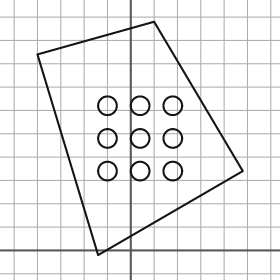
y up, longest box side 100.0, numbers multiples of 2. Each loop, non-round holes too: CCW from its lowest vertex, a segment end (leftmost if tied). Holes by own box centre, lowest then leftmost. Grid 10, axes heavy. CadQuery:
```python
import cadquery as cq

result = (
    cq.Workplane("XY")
    .moveTo(-14.0, -2.0)
    .lineTo(48.0, 34.0)
    .lineTo(10.0, 98.0)
    .lineTo(-40.0, 84.0)
    .close()
    .moveTo(-10.0, 34.0)
    .circle(4.0)
    .moveTo(4.0, 34.0)
    .circle(4.0)
    .moveTo(18.0, 34.0)
    .circle(4.0)
    .moveTo(-10.0, 48.0)
    .circle(4.0)
    .moveTo(4.0, 48.0)
    .circle(4.0)
    .moveTo(18.0, 48.0)
    .circle(4.0)
    .moveTo(-10.0, 62.0)
    .circle(4.0)
    .moveTo(4.0, 62.0)
    .circle(4.0)
    .moveTo(18.0, 62.0)
    .circle(4.0)
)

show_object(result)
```